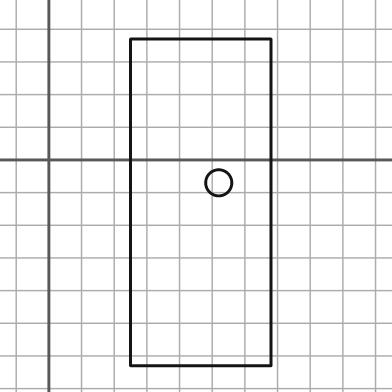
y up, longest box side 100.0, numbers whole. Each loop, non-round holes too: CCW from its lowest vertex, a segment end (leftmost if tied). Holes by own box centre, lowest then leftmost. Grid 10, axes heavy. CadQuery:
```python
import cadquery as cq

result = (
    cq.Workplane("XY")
    .moveTo(25.0, -63.0)
    .lineTo(68.0, -63.0)
    .lineTo(68.0, 37.0)
    .lineTo(25.0, 37.0)
    .close()
    .moveTo(52.0, -7.0)
    .circle(4.0)
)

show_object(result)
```